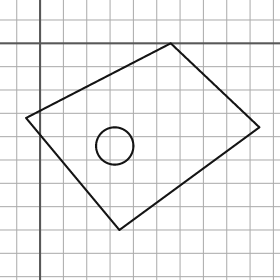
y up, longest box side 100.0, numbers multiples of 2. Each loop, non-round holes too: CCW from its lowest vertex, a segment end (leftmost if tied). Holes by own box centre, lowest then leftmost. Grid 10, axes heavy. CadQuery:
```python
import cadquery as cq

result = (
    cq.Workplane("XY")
    .moveTo(34.0, -80.0)
    .lineTo(94.0, -36.0)
    .lineTo(56.0, 0.0)
    .lineTo(-6.0, -32.0)
    .close()
    .moveTo(32.0, -44.0)
    .circle(8.0)
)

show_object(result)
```